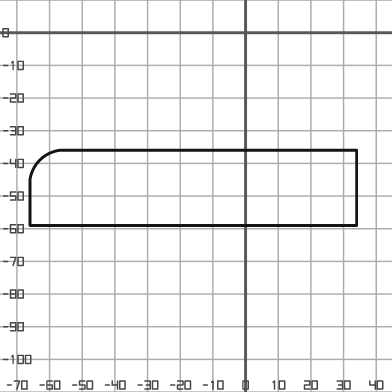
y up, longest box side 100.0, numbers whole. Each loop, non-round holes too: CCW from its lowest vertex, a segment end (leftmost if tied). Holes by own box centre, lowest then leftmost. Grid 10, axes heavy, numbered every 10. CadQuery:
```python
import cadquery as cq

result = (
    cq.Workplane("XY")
    .moveTo(-66.0, -59.0)
    .lineTo(34.0, -59.0)
    .lineTo(34.0, -36.0)
    .lineTo(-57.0, -36.0)
    .threePointArc((-63.0, -39.0), (-66.0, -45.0))
    .close()
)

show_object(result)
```